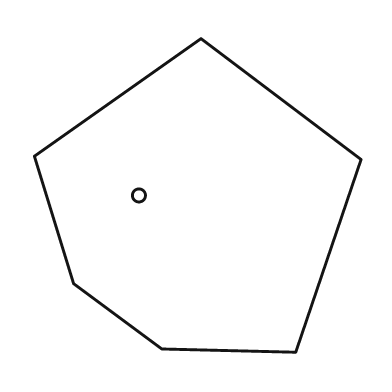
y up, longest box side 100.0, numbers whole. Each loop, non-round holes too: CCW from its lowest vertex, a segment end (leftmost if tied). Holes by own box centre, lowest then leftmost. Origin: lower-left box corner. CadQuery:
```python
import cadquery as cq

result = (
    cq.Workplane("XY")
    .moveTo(80.0, 0.0)
    .lineTo(100.0, 59.0)
    .lineTo(51.0, 96.0)
    .lineTo(0.0, 60.0)
    .lineTo(12.0, 21.0)
    .lineTo(39.0, 1.0)
    .close()
    .moveTo(32.0, 48.0)
    .circle(2.0)
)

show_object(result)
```